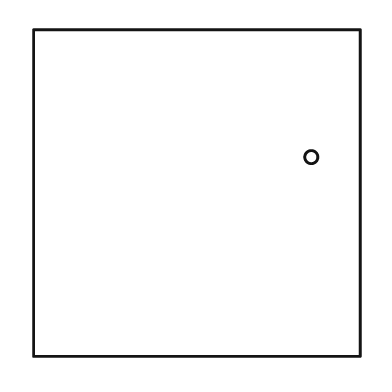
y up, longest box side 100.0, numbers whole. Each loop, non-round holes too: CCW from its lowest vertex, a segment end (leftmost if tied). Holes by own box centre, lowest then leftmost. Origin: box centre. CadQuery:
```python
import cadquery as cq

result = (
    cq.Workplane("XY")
    .moveTo(-50.0, -50.0)
    .lineTo(50.0, -50.0)
    .lineTo(50.0, 50.0)
    .lineTo(-50.0, 50.0)
    .close()
    .moveTo(35.0, 11.0)
    .circle(2.0)
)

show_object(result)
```